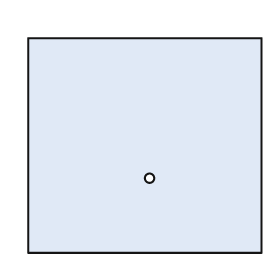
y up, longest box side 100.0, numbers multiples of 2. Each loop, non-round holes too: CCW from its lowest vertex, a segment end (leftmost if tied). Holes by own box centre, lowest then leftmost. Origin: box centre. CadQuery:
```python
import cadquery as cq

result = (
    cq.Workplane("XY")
    .moveTo(-50.0, -46.0)
    .lineTo(50.0, -46.0)
    .lineTo(50.0, 46.0)
    .lineTo(-50.0, 46.0)
    .close()
    .moveTo(2.0, -14.0)
    .circle(2.0)
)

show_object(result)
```